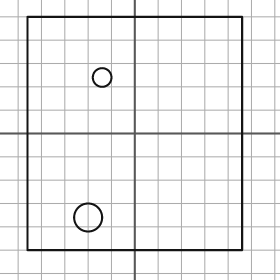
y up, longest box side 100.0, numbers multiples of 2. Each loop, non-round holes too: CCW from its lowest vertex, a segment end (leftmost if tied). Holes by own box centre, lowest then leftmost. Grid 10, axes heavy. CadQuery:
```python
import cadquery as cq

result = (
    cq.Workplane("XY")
    .moveTo(-46.0, -50.0)
    .lineTo(46.0, -50.0)
    .lineTo(46.0, 50.0)
    .lineTo(-46.0, 50.0)
    .close()
    .moveTo(-20.0, -36.0)
    .circle(6.0)
    .moveTo(-14.0, 24.0)
    .circle(4.0)
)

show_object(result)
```